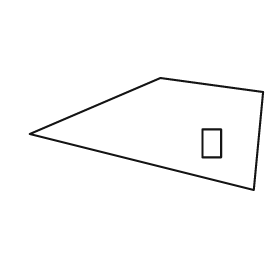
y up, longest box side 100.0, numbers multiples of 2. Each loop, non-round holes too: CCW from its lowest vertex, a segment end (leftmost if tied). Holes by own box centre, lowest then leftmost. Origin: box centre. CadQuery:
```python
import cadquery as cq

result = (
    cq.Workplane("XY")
    .moveTo(46.0, -24.0)
    .lineTo(50.0, 18.0)
    .lineTo(6.0, 24.0)
    .lineTo(-50.0, 0.0)
    .close()
    .moveTo(24.0, -10.0)
    .lineTo(32.0, -10.0)
    .lineTo(32.0, 2.0)
    .lineTo(24.0, 2.0)
    .close()
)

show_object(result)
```